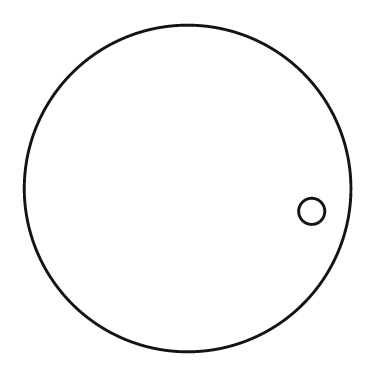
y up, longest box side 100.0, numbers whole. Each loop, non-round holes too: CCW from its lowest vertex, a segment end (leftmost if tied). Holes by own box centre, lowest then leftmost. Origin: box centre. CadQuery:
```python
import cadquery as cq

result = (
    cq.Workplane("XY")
    .moveTo(0.0, 0.0)
    .circle(50.0)
    .moveTo(38.0, -7.0)
    .circle(4.0)
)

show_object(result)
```